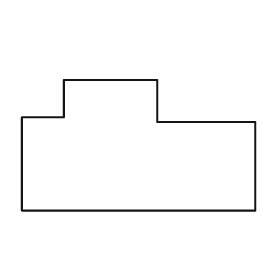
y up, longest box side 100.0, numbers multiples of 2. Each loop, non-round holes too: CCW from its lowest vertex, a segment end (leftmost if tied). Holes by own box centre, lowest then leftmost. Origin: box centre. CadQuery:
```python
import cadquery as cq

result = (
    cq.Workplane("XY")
    .moveTo(-50.0, -28.0)
    .lineTo(50.0, -28.0)
    .lineTo(50.0, 10.0)
    .lineTo(8.0, 10.0)
    .lineTo(8.0, 28.0)
    .lineTo(-32.0, 28.0)
    .lineTo(-32.0, 12.0)
    .lineTo(-50.0, 12.0)
    .close()
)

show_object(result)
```